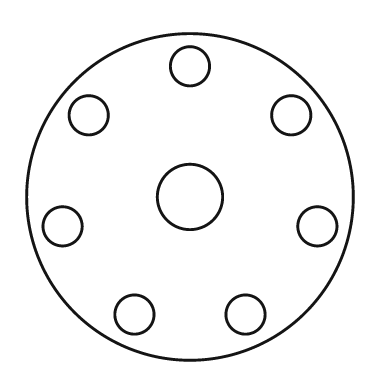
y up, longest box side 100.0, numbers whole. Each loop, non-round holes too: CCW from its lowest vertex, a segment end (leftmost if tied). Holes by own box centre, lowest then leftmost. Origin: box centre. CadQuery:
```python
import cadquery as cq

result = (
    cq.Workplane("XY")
    .moveTo(0.0, 0.0)
    .circle(50.0)
    .moveTo(-17.0, -36.0)
    .circle(6.0)
    .moveTo(17.0, -36.0)
    .circle(6.0)
    .moveTo(-39.0, -9.0)
    .circle(6.0)
    .moveTo(39.0, -9.0)
    .circle(6.0)
    .moveTo(0.0, 0.0)
    .circle(10.0)
    .moveTo(-31.0, 25.0)
    .circle(6.0)
    .moveTo(31.0, 25.0)
    .circle(6.0)
    .moveTo(0.0, 40.0)
    .circle(6.0)
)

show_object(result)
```